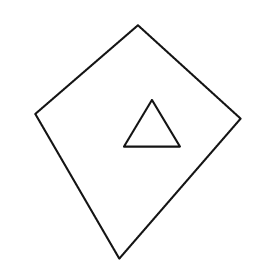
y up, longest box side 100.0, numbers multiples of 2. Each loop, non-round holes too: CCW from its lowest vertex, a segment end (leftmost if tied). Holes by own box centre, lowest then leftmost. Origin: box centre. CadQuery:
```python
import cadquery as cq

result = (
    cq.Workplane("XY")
    .moveTo(-8.0, -50.0)
    .lineTo(44.0, 10.0)
    .lineTo(0.0, 50.0)
    .lineTo(-44.0, 12.0)
    .close()
    .moveTo(-6.0, -2.0)
    .lineTo(18.0, -2.0)
    .lineTo(6.0, 18.0)
    .close()
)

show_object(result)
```